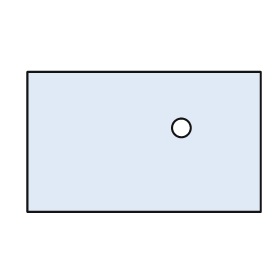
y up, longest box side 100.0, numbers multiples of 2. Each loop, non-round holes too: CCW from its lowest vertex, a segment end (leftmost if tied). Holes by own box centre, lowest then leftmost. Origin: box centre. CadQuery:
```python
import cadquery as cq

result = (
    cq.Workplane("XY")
    .moveTo(-50.0, -30.0)
    .lineTo(50.0, -30.0)
    .lineTo(50.0, 30.0)
    .lineTo(-50.0, 30.0)
    .close()
    .moveTo(16.0, 6.0)
    .circle(4.0)
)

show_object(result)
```